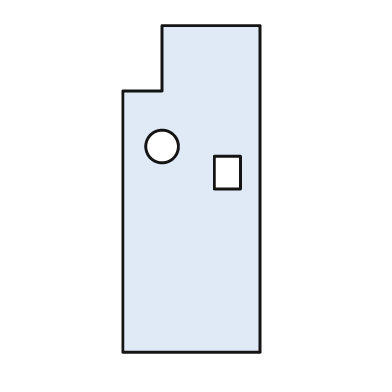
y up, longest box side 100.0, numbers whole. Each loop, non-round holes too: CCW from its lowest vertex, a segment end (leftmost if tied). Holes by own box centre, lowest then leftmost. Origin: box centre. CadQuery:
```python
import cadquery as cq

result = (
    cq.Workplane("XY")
    .moveTo(-21.0, -50.0)
    .lineTo(21.0, -50.0)
    .lineTo(21.0, 50.0)
    .lineTo(-9.0, 50.0)
    .lineTo(-9.0, 30.0)
    .lineTo(-21.0, 30.0)
    .close()
    .moveTo(7.0, 0.0)
    .lineTo(15.0, 0.0)
    .lineTo(15.0, 10.0)
    .lineTo(7.0, 10.0)
    .close()
    .moveTo(-9.0, 13.0)
    .circle(5.0)
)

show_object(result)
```